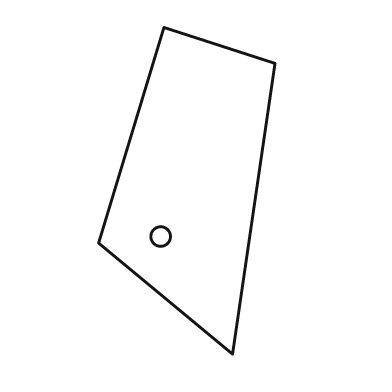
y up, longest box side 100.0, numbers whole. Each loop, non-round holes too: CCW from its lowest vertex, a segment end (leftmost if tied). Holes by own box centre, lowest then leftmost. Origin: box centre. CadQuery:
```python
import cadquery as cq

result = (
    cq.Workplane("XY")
    .moveTo(14.0, -50.0)
    .lineTo(27.0, 39.0)
    .lineTo(-7.0, 50.0)
    .lineTo(-27.0, -16.0)
    .close()
    .moveTo(-8.0, -14.0)
    .circle(3.0)
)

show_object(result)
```